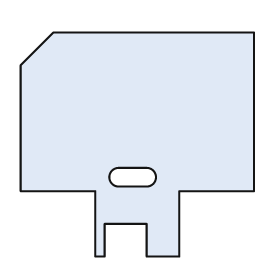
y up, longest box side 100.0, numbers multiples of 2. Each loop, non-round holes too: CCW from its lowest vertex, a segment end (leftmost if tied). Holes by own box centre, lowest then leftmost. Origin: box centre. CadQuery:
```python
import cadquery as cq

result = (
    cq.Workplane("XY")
    .moveTo(-18.0, -48.0)
    .lineTo(-14.0, -48.0)
    .lineTo(-14.0, -34.0)
    .lineTo(4.0, -34.0)
    .lineTo(4.0, -48.0)
    .lineTo(18.0, -48.0)
    .lineTo(18.0, -20.0)
    .lineTo(50.0, -20.0)
    .lineTo(50.0, 48.0)
    .lineTo(-36.0, 48.0)
    .lineTo(-50.0, 34.0)
    .lineTo(-50.0, -20.0)
    .lineTo(-18.0, -20.0)
    .close()
    .moveTo(-8.0, -18.0)
    .lineTo(4.0, -18.0)
    .threePointArc((8.0, -14.0), (4.0, -10.0))
    .lineTo(-8.0, -10.0)
    .threePointArc((-12.0, -14.0), (-8.0, -18.0))
    .close()
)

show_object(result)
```